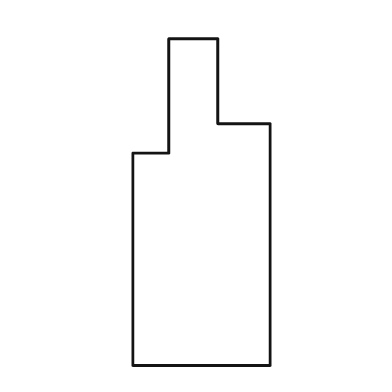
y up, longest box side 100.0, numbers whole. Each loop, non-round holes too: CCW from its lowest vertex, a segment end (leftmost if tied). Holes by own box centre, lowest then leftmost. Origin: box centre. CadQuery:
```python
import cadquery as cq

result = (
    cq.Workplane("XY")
    .moveTo(-21.0, -50.0)
    .lineTo(21.0, -50.0)
    .lineTo(21.0, 24.0)
    .lineTo(5.0, 24.0)
    .lineTo(5.0, 50.0)
    .lineTo(-10.0, 50.0)
    .lineTo(-10.0, 15.0)
    .lineTo(-21.0, 15.0)
    .close()
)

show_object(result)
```